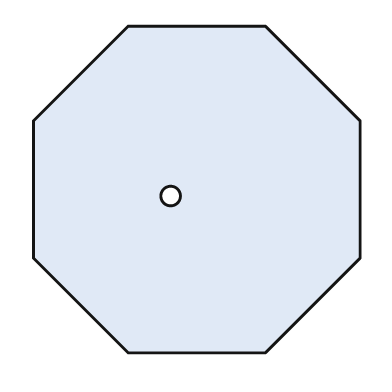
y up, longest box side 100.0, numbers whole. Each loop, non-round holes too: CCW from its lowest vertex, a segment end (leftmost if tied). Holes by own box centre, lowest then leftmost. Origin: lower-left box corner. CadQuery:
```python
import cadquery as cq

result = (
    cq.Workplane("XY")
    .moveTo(29.0, 0.0)
    .lineTo(71.0, 0.0)
    .lineTo(100.0, 29.0)
    .lineTo(100.0, 71.0)
    .lineTo(71.0, 100.0)
    .lineTo(29.0, 100.0)
    .lineTo(0.0, 71.0)
    .lineTo(0.0, 29.0)
    .close()
    .moveTo(42.0, 48.0)
    .circle(3.0)
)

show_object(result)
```